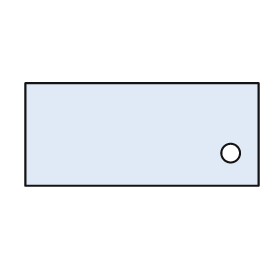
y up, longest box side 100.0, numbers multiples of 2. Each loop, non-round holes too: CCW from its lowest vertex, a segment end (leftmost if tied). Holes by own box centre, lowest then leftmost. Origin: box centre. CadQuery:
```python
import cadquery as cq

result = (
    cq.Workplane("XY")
    .moveTo(-50.0, -22.0)
    .lineTo(50.0, -22.0)
    .lineTo(50.0, 22.0)
    .lineTo(-50.0, 22.0)
    .close()
    .moveTo(38.0, -8.0)
    .circle(4.0)
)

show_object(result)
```